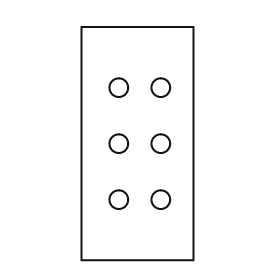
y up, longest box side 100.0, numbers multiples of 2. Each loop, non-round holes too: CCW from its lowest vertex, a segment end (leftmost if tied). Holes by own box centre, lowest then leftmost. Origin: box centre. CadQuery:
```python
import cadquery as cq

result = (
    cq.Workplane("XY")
    .moveTo(-24.0, -50.0)
    .lineTo(24.0, -50.0)
    .lineTo(24.0, 50.0)
    .lineTo(-24.0, 50.0)
    .close()
    .moveTo(-8.0, -24.0)
    .circle(4.0)
    .moveTo(10.0, -24.0)
    .circle(4.0)
    .moveTo(-8.0, 0.0)
    .circle(4.0)
    .moveTo(10.0, 0.0)
    .circle(4.0)
    .moveTo(-8.0, 24.0)
    .circle(4.0)
    .moveTo(10.0, 24.0)
    .circle(4.0)
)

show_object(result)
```